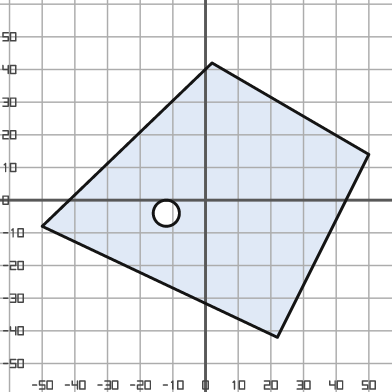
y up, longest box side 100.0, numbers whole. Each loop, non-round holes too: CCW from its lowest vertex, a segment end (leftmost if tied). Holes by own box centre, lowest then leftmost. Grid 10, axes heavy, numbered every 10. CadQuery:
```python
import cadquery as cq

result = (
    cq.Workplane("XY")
    .moveTo(22.0, -42.0)
    .lineTo(50.0, 14.0)
    .lineTo(2.0, 42.0)
    .lineTo(-50.0, -8.0)
    .close()
    .moveTo(-12.0, -4.0)
    .circle(4.0)
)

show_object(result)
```